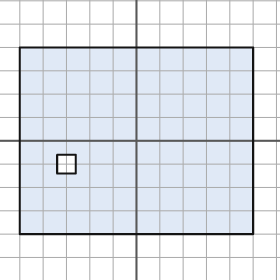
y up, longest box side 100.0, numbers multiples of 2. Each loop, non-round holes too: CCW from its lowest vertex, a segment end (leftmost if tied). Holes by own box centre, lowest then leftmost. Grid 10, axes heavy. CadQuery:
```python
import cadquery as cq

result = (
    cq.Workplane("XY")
    .moveTo(-50.0, -40.0)
    .lineTo(50.0, -40.0)
    .lineTo(50.0, 40.0)
    .lineTo(-50.0, 40.0)
    .close()
    .moveTo(-34.0, -14.0)
    .lineTo(-26.0, -14.0)
    .lineTo(-26.0, -6.0)
    .lineTo(-34.0, -6.0)
    .close()
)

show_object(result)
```